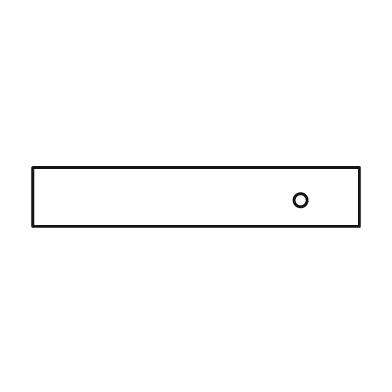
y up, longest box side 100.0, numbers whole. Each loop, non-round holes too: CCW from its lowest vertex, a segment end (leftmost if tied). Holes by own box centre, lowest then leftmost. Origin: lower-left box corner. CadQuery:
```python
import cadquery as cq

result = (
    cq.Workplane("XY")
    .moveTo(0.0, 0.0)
    .lineTo(100.0, 0.0)
    .lineTo(100.0, 18.0)
    .lineTo(0.0, 18.0)
    .close()
    .moveTo(82.0, 8.0)
    .circle(2.0)
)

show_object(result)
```